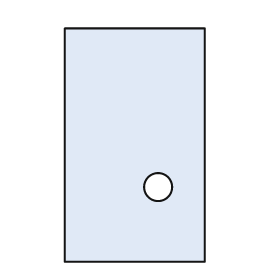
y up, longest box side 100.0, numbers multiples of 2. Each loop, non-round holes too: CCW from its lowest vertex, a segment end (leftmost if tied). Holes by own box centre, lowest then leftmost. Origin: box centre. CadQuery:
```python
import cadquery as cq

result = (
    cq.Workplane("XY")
    .moveTo(-30.0, -50.0)
    .lineTo(30.0, -50.0)
    .lineTo(30.0, 50.0)
    .lineTo(-30.0, 50.0)
    .close()
    .moveTo(10.0, -18.0)
    .circle(6.0)
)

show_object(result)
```